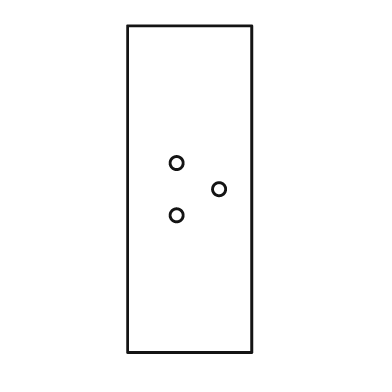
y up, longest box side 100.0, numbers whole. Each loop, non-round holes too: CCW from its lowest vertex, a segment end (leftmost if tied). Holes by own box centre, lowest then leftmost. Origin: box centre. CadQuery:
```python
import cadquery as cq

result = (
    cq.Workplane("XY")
    .moveTo(-19.0, -50.0)
    .lineTo(19.0, -50.0)
    .lineTo(19.0, 50.0)
    .lineTo(-19.0, 50.0)
    .close()
    .moveTo(-4.0, -8.0)
    .circle(2.0)
    .moveTo(9.0, 0.0)
    .circle(2.0)
    .moveTo(-4.0, 8.0)
    .circle(2.0)
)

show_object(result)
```